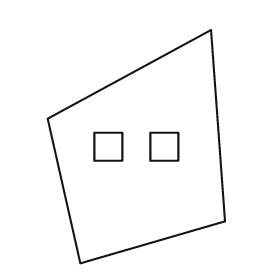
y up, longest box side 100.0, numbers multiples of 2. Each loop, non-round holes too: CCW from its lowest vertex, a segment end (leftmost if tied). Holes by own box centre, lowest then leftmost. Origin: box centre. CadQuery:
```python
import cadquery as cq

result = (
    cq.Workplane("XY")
    .moveTo(-24.0, -50.0)
    .lineTo(38.0, -32.0)
    .lineTo(32.0, 50.0)
    .lineTo(-38.0, 12.0)
    .close()
    .moveTo(-18.0, -6.0)
    .lineTo(-6.0, -6.0)
    .lineTo(-6.0, 6.0)
    .lineTo(-18.0, 6.0)
    .close()
    .moveTo(6.0, -6.0)
    .lineTo(18.0, -6.0)
    .lineTo(18.0, 6.0)
    .lineTo(6.0, 6.0)
    .close()
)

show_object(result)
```